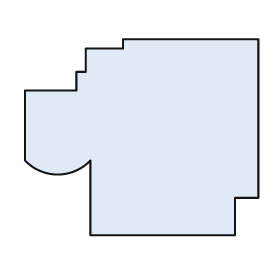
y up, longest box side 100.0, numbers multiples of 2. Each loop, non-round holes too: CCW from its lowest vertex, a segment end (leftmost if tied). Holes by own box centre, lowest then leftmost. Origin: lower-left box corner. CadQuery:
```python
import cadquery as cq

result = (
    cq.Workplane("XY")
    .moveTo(28.0, 0.0)
    .lineTo(90.0, 0.0)
    .lineTo(90.0, 16.0)
    .lineTo(100.0, 16.0)
    .lineTo(100.0, 84.0)
    .lineTo(42.0, 84.0)
    .lineTo(42.0, 80.0)
    .lineTo(26.0, 80.0)
    .lineTo(26.0, 70.0)
    .lineTo(22.0, 70.0)
    .lineTo(22.0, 62.0)
    .lineTo(0.0, 62.0)
    .lineTo(0.0, 32.0)
    .threePointArc((14.0, 26.0), (28.0, 32.0))
    .close()
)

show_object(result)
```